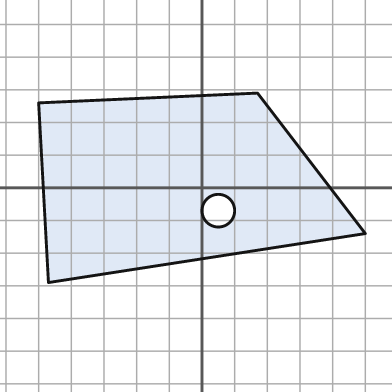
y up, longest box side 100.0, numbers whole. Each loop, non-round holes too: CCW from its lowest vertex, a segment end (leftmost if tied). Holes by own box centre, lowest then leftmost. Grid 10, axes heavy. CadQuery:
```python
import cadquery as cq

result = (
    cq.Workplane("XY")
    .moveTo(-47.0, -29.0)
    .lineTo(50.0, -14.0)
    .lineTo(17.0, 29.0)
    .lineTo(-50.0, 26.0)
    .close()
    .moveTo(5.0, -7.0)
    .circle(5.0)
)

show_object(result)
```